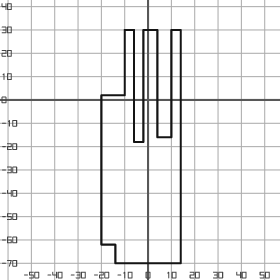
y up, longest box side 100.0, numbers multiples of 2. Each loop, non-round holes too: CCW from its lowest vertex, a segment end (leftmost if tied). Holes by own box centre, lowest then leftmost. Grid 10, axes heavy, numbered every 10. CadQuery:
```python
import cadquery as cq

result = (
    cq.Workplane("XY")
    .moveTo(-14.0, -70.0)
    .lineTo(14.0, -70.0)
    .lineTo(14.0, 30.0)
    .lineTo(10.0, 30.0)
    .lineTo(10.0, -16.0)
    .lineTo(4.0, -16.0)
    .lineTo(4.0, 30.0)
    .lineTo(-2.0, 30.0)
    .lineTo(-2.0, -18.0)
    .lineTo(-6.0, -18.0)
    .lineTo(-6.0, 30.0)
    .lineTo(-10.0, 30.0)
    .lineTo(-10.0, 2.0)
    .lineTo(-20.0, 2.0)
    .lineTo(-20.0, -62.0)
    .lineTo(-14.0, -62.0)
    .close()
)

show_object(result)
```